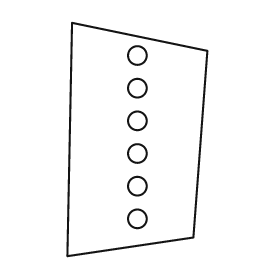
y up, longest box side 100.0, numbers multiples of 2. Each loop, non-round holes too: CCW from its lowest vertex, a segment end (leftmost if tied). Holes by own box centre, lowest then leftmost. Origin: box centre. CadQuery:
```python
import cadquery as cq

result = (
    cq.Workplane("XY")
    .moveTo(-30.0, -50.0)
    .lineTo(24.0, -42.0)
    .lineTo(30.0, 38.0)
    .lineTo(-28.0, 50.0)
    .close()
    .moveTo(0.0, -34.0)
    .circle(4.0)
    .moveTo(0.0, -20.0)
    .circle(4.0)
    .moveTo(0.0, -6.0)
    .circle(4.0)
    .moveTo(0.0, 8.0)
    .circle(4.0)
    .moveTo(0.0, 22.0)
    .circle(4.0)
    .moveTo(0.0, 36.0)
    .circle(4.0)
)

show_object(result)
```